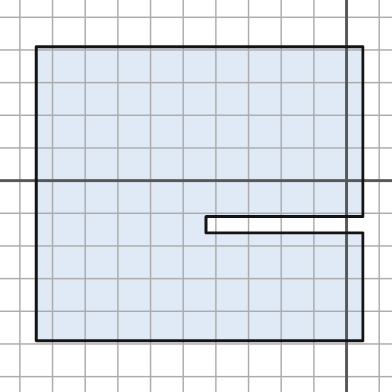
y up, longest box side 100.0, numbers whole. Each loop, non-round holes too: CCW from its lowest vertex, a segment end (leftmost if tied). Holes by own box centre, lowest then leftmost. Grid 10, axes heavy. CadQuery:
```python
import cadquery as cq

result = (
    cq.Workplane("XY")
    .moveTo(-95.0, -49.0)
    .lineTo(5.0, -49.0)
    .lineTo(5.0, -16.0)
    .lineTo(-43.0, -16.0)
    .lineTo(-43.0, -11.0)
    .lineTo(5.0, -11.0)
    .lineTo(5.0, 41.0)
    .lineTo(-95.0, 41.0)
    .close()
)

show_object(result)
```